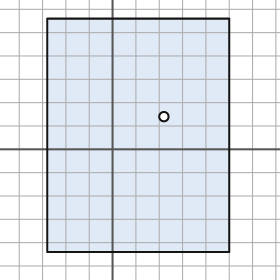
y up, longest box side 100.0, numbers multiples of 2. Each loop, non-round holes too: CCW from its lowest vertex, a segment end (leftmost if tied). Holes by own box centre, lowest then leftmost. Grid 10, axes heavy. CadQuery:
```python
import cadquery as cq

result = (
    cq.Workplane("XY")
    .moveTo(-28.0, -44.0)
    .lineTo(50.0, -44.0)
    .lineTo(50.0, 56.0)
    .lineTo(-28.0, 56.0)
    .close()
    .moveTo(22.0, 14.0)
    .circle(2.0)
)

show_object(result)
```